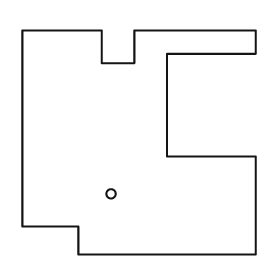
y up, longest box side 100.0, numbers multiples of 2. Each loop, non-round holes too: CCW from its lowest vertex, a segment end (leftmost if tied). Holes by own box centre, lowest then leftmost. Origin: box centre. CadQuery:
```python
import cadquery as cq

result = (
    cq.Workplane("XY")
    .moveTo(-26.0, -48.0)
    .lineTo(50.0, -48.0)
    .lineTo(50.0, -6.0)
    .lineTo(12.0, -6.0)
    .lineTo(12.0, 38.0)
    .lineTo(50.0, 38.0)
    .lineTo(50.0, 48.0)
    .lineTo(-2.0, 48.0)
    .lineTo(-2.0, 34.0)
    .lineTo(-16.0, 34.0)
    .lineTo(-16.0, 48.0)
    .lineTo(-50.0, 48.0)
    .lineTo(-50.0, -36.0)
    .lineTo(-26.0, -36.0)
    .close()
    .moveTo(-12.0, -22.0)
    .circle(2.0)
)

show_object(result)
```